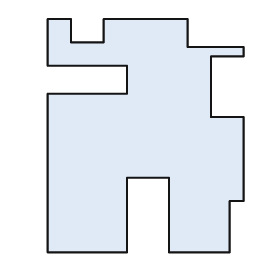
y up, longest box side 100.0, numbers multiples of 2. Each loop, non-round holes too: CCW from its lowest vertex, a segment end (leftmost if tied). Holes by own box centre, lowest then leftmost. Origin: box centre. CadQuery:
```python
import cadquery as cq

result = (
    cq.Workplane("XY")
    .moveTo(-42.0, -50.0)
    .lineTo(-8.0, -50.0)
    .lineTo(-8.0, -18.0)
    .lineTo(10.0, -18.0)
    .lineTo(10.0, -50.0)
    .lineTo(36.0, -50.0)
    .lineTo(36.0, -28.0)
    .lineTo(42.0, -28.0)
    .lineTo(42.0, 8.0)
    .lineTo(28.0, 8.0)
    .lineTo(28.0, 34.0)
    .lineTo(42.0, 34.0)
    .lineTo(42.0, 38.0)
    .lineTo(18.0, 38.0)
    .lineTo(18.0, 50.0)
    .lineTo(-18.0, 50.0)
    .lineTo(-18.0, 40.0)
    .lineTo(-32.0, 40.0)
    .lineTo(-32.0, 50.0)
    .lineTo(-42.0, 50.0)
    .lineTo(-42.0, 30.0)
    .lineTo(-8.0, 30.0)
    .lineTo(-8.0, 18.0)
    .lineTo(-42.0, 18.0)
    .close()
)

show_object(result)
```